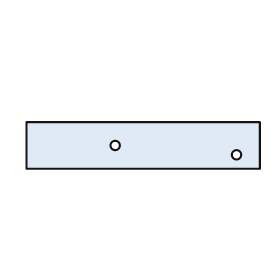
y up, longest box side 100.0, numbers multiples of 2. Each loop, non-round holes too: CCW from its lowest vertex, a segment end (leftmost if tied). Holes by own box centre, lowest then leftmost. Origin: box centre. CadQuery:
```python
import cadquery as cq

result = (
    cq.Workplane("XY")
    .moveTo(-50.0, -10.0)
    .lineTo(50.0, -10.0)
    .lineTo(50.0, 10.0)
    .lineTo(-50.0, 10.0)
    .close()
    .moveTo(40.0, -4.0)
    .circle(2.0)
    .moveTo(-12.0, 0.0)
    .circle(2.0)
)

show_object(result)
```